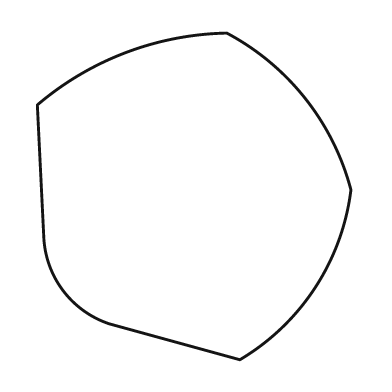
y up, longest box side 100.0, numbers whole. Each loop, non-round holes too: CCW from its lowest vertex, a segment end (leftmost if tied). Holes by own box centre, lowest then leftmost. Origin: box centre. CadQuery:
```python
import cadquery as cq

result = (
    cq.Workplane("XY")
    .moveTo(14.0, -50.0)
    .threePointArc((37.0, -28.0), (48.0, 2.0))
    .threePointArc((34.0, 30.0), (10.0, 50.0))
    .threePointArc((-21.0, 44.0), (-48.0, 28.0))
    .lineTo(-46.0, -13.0)
    .threePointArc((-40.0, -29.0), (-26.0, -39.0))
    .close()
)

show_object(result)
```